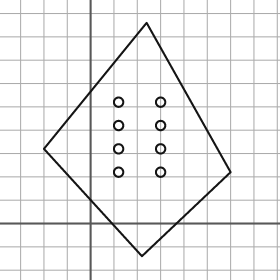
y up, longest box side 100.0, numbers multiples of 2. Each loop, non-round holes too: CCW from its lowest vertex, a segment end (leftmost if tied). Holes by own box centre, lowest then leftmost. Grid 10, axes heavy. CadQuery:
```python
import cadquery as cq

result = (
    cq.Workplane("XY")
    .moveTo(22.0, -14.0)
    .lineTo(60.0, 22.0)
    .lineTo(24.0, 86.0)
    .lineTo(-20.0, 32.0)
    .close()
    .moveTo(12.0, 22.0)
    .circle(2.0)
    .moveTo(30.0, 22.0)
    .circle(2.0)
    .moveTo(12.0, 32.0)
    .circle(2.0)
    .moveTo(30.0, 32.0)
    .circle(2.0)
    .moveTo(12.0, 42.0)
    .circle(2.0)
    .moveTo(30.0, 42.0)
    .circle(2.0)
    .moveTo(12.0, 52.0)
    .circle(2.0)
    .moveTo(30.0, 52.0)
    .circle(2.0)
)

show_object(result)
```